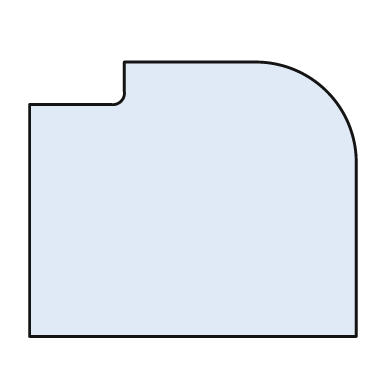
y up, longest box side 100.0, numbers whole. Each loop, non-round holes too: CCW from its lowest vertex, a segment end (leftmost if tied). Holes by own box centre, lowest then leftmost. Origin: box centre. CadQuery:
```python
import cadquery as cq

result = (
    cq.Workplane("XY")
    .moveTo(-50.0, -42.0)
    .lineTo(50.0, -42.0)
    .lineTo(50.0, 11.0)
    .threePointArc((41.0, 33.0), (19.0, 42.0))
    .lineTo(-21.0, 42.0)
    .lineTo(-21.0, 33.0)
    .threePointArc((-22.0, 30.0), (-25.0, 29.0))
    .lineTo(-50.0, 29.0)
    .close()
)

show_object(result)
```